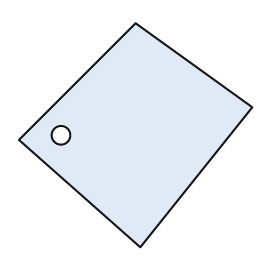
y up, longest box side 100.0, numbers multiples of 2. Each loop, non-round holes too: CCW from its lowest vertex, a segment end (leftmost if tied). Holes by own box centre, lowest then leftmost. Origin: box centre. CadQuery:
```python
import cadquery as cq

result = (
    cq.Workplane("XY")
    .moveTo(2.0, -48.0)
    .lineTo(50.0, 12.0)
    .lineTo(0.0, 48.0)
    .lineTo(-50.0, -2.0)
    .close()
    .moveTo(-32.0, 0.0)
    .circle(4.0)
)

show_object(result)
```